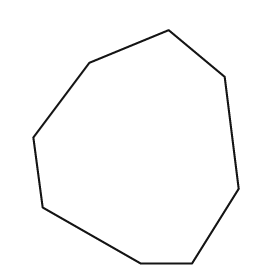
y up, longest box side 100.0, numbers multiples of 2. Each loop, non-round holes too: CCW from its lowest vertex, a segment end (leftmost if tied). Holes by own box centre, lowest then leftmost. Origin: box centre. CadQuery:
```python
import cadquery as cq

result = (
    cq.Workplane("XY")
    .moveTo(2.0, -50.0)
    .lineTo(24.0, -50.0)
    .lineTo(44.0, -18.0)
    .lineTo(38.0, 30.0)
    .lineTo(14.0, 50.0)
    .lineTo(-20.0, 36.0)
    .lineTo(-44.0, 4.0)
    .lineTo(-40.0, -26.0)
    .close()
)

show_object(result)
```